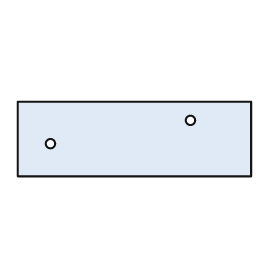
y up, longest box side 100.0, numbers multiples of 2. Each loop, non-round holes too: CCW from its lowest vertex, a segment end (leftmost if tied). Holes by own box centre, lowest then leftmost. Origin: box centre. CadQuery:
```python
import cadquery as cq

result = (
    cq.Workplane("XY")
    .moveTo(-50.0, -16.0)
    .lineTo(50.0, -16.0)
    .lineTo(50.0, 16.0)
    .lineTo(-50.0, 16.0)
    .close()
    .moveTo(-36.0, -2.0)
    .circle(2.0)
    .moveTo(24.0, 8.0)
    .circle(2.0)
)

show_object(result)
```